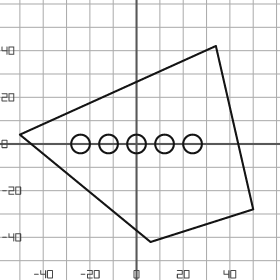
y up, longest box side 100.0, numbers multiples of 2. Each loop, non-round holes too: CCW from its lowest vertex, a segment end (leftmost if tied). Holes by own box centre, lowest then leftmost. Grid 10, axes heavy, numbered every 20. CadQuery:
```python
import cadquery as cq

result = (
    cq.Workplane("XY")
    .moveTo(6.0, -42.0)
    .lineTo(50.0, -28.0)
    .lineTo(34.0, 42.0)
    .lineTo(-50.0, 4.0)
    .close()
    .moveTo(-24.0, 0.0)
    .circle(4.0)
    .moveTo(-12.0, 0.0)
    .circle(4.0)
    .moveTo(0.0, 0.0)
    .circle(4.0)
    .moveTo(12.0, 0.0)
    .circle(4.0)
    .moveTo(24.0, 0.0)
    .circle(4.0)
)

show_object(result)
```